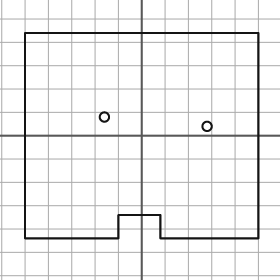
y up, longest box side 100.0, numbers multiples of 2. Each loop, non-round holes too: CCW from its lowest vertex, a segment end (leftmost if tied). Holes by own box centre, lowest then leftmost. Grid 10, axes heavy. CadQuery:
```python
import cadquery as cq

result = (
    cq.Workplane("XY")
    .moveTo(-50.0, -44.0)
    .lineTo(-10.0, -44.0)
    .lineTo(-10.0, -34.0)
    .lineTo(8.0, -34.0)
    .lineTo(8.0, -44.0)
    .lineTo(50.0, -44.0)
    .lineTo(50.0, 44.0)
    .lineTo(-50.0, 44.0)
    .close()
    .moveTo(28.0, 4.0)
    .circle(2.0)
    .moveTo(-16.0, 8.0)
    .circle(2.0)
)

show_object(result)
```